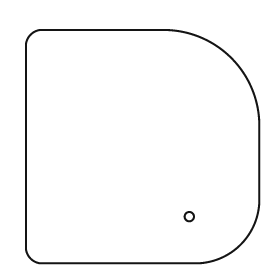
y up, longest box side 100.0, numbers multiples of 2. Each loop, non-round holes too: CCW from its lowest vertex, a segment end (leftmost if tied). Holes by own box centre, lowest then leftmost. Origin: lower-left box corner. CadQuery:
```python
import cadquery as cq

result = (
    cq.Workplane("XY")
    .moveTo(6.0, 0.0)
    .lineTo(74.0, 0.0)
    .threePointArc((92.0, 8.0), (100.0, 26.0))
    .lineTo(100.0, 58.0)
    .threePointArc((88.0, 88.0), (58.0, 100.0))
    .lineTo(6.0, 100.0)
    .threePointArc((2.0, 98.0), (0.0, 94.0))
    .lineTo(0.0, 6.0)
    .threePointArc((2.0, 2.0), (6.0, 0.0))
    .close()
    .moveTo(70.0, 20.0)
    .circle(2.0)
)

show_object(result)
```